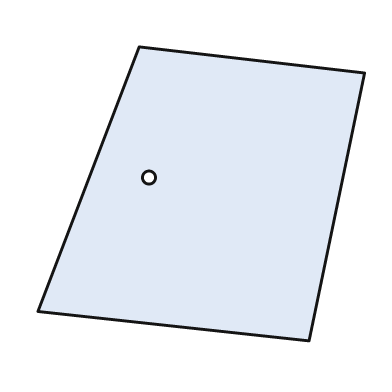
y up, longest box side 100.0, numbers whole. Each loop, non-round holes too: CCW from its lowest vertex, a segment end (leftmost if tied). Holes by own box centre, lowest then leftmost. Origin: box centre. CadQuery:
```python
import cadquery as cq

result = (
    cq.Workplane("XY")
    .moveTo(33.0, -45.0)
    .lineTo(50.0, 37.0)
    .lineTo(-19.0, 45.0)
    .lineTo(-50.0, -36.0)
    .close()
    .moveTo(-16.0, 5.0)
    .circle(2.0)
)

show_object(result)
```